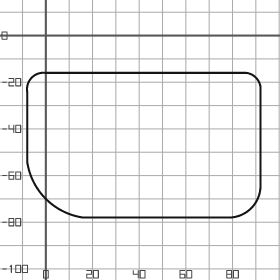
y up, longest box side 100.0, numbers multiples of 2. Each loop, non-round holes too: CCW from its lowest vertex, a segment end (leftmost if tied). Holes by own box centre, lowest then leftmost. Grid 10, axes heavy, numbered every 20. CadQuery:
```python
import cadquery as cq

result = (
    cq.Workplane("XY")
    .moveTo(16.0, -78.0)
    .lineTo(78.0, -78.0)
    .threePointArc((88.0, -74.0), (92.0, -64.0))
    .lineTo(92.0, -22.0)
    .threePointArc((90.0, -18.0), (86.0, -16.0))
    .lineTo(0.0, -16.0)
    .threePointArc((-6.0, -18.0), (-8.0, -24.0))
    .lineTo(-8.0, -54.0)
    .threePointArc((0.0, -70.0), (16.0, -78.0))
    .close()
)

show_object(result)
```